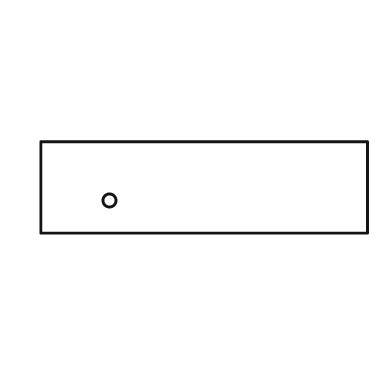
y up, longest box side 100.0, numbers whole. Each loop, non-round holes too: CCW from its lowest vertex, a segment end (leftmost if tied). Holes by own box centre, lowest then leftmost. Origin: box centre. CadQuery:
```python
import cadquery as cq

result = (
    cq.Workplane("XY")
    .moveTo(-50.0, -14.0)
    .lineTo(50.0, -14.0)
    .lineTo(50.0, 14.0)
    .lineTo(-50.0, 14.0)
    .close()
    .moveTo(-29.0, -4.0)
    .circle(2.0)
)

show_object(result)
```